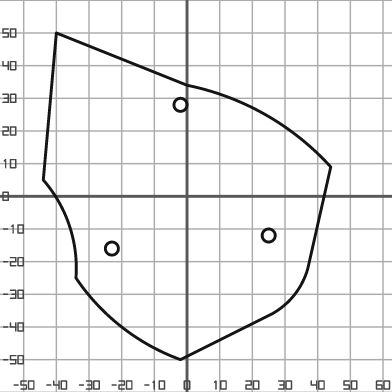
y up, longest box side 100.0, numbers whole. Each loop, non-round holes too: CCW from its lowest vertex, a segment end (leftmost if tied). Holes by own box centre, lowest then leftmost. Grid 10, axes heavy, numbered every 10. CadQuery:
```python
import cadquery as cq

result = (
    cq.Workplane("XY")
    .moveTo(-2.0, -50.0)
    .lineTo(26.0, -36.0)
    .threePointArc((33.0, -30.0), (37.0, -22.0))
    .lineTo(44.0, 9.0)
    .threePointArc((24.0, 25.0), (0.0, 34.0))
    .lineTo(-40.0, 50.0)
    .lineTo(-44.0, 5.0)
    .threePointArc((-36.0, -9.0), (-34.0, -25.0))
    .threePointArc((-20.0, -40.0), (-2.0, -50.0))
    .close()
    .moveTo(-23.0, -16.0)
    .circle(2.0)
    .moveTo(25.0, -12.0)
    .circle(2.0)
    .moveTo(-2.0, 28.0)
    .circle(2.0)
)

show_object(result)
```